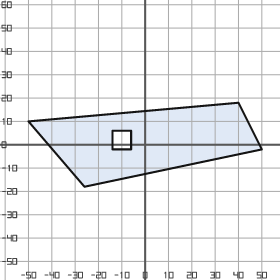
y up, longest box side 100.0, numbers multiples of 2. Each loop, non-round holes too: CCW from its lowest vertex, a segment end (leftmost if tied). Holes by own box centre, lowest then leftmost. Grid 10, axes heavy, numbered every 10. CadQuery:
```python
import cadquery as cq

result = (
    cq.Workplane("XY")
    .moveTo(-26.0, -18.0)
    .lineTo(50.0, -2.0)
    .lineTo(40.0, 18.0)
    .lineTo(-50.0, 10.0)
    .close()
    .moveTo(-14.0, -2.0)
    .lineTo(-6.0, -2.0)
    .lineTo(-6.0, 6.0)
    .lineTo(-14.0, 6.0)
    .close()
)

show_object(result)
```